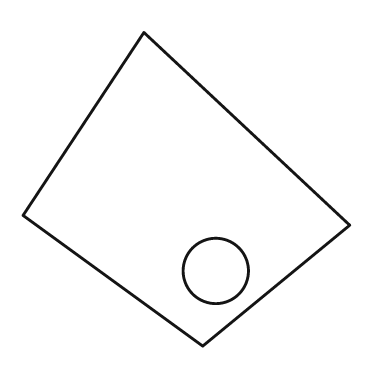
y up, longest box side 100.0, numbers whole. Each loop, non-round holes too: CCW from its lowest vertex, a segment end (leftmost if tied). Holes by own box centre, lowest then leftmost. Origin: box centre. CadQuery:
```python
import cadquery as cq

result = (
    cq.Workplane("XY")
    .moveTo(5.0, -48.0)
    .lineTo(50.0, -11.0)
    .lineTo(-13.0, 48.0)
    .lineTo(-50.0, -8.0)
    .close()
    .moveTo(9.0, -25.0)
    .circle(10.0)
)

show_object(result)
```